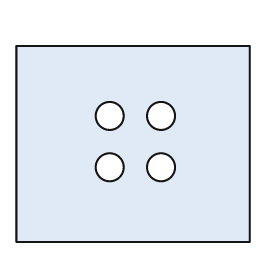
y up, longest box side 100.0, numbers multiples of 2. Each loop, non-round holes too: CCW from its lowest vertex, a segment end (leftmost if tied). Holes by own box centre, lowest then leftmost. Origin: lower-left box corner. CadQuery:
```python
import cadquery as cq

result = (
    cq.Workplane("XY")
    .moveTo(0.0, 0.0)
    .lineTo(100.0, 0.0)
    .lineTo(100.0, 84.0)
    .lineTo(0.0, 84.0)
    .close()
    .moveTo(40.0, 32.0)
    .circle(6.0)
    .moveTo(62.0, 32.0)
    .circle(6.0)
    .moveTo(40.0, 54.0)
    .circle(6.0)
    .moveTo(62.0, 54.0)
    .circle(6.0)
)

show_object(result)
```